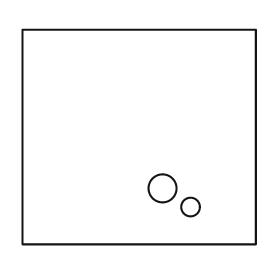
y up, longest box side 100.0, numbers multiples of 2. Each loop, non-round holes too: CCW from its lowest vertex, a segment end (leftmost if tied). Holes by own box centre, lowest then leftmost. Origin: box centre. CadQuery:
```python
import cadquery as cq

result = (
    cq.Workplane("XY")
    .moveTo(-50.0, -46.0)
    .lineTo(50.0, -46.0)
    .lineTo(50.0, 46.0)
    .lineTo(-50.0, 46.0)
    .close()
    .moveTo(22.0, -30.0)
    .circle(4.0)
    .moveTo(10.0, -22.0)
    .circle(6.0)
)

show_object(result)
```